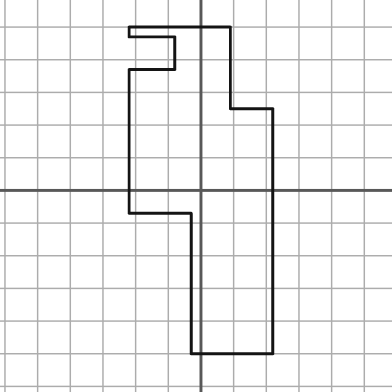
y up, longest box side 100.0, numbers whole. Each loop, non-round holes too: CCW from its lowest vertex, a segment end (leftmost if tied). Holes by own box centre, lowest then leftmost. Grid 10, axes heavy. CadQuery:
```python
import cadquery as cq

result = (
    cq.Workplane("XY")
    .moveTo(-3.0, -50.0)
    .lineTo(22.0, -50.0)
    .lineTo(22.0, 25.0)
    .lineTo(9.0, 25.0)
    .lineTo(9.0, 50.0)
    .lineTo(-22.0, 50.0)
    .lineTo(-22.0, 47.0)
    .lineTo(-8.0, 47.0)
    .lineTo(-8.0, 37.0)
    .lineTo(-22.0, 37.0)
    .lineTo(-22.0, -7.0)
    .lineTo(-3.0, -7.0)
    .close()
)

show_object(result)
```